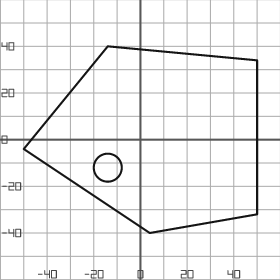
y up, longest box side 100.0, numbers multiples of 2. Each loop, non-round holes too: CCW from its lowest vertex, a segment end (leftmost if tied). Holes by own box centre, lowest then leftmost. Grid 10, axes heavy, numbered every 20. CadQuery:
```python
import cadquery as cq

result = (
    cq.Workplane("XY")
    .moveTo(4.0, -40.0)
    .lineTo(50.0, -32.0)
    .lineTo(50.0, 34.0)
    .lineTo(-14.0, 40.0)
    .lineTo(-50.0, -4.0)
    .close()
    .moveTo(-14.0, -12.0)
    .circle(6.0)
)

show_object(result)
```